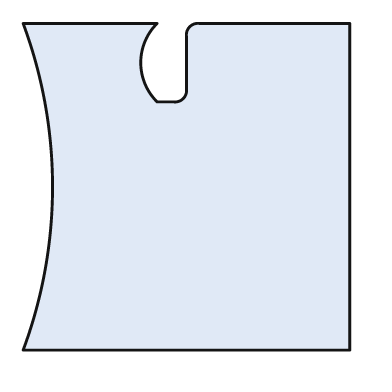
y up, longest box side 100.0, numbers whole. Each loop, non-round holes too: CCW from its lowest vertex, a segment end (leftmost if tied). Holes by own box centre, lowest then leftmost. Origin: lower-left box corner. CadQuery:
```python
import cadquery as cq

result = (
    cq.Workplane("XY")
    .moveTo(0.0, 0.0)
    .lineTo(100.0, 0.0)
    .lineTo(100.0, 100.0)
    .lineTo(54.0, 100.0)
    .threePointArc((51.0, 99.0), (50.0, 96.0))
    .lineTo(50.0, 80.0)
    .threePointArc((49.0, 77.0), (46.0, 76.0))
    .lineTo(41.0, 76.0)
    .threePointArc((36.0, 88.0), (41.0, 100.0))
    .lineTo(0.0, 100.0)
    .threePointArc((9.0, 50.0), (0.0, 0.0))
    .close()
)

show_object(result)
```